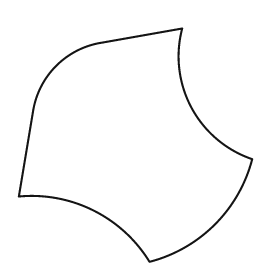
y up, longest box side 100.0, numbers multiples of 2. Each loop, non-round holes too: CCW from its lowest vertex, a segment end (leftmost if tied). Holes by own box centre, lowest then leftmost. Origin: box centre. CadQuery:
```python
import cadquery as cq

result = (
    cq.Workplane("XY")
    .moveTo(6.0, -50.0)
    .threePointArc((34.0, -34.0), (50.0, -6.0))
    .threePointArc((24.0, 16.0), (20.0, 50.0))
    .lineTo(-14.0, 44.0)
    .threePointArc((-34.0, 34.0), (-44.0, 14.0))
    .lineTo(-50.0, -22.0)
    .threePointArc((-18.0, -28.0), (6.0, -50.0))
    .close()
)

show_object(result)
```